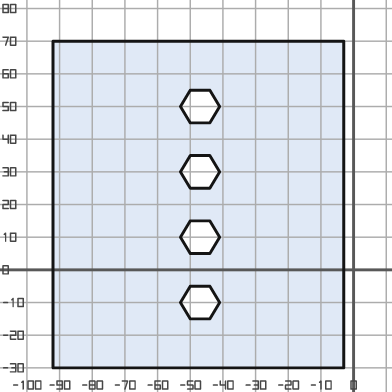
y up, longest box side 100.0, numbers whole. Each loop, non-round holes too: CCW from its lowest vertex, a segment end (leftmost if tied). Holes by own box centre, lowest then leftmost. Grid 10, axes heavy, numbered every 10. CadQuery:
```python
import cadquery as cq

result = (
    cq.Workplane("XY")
    .moveTo(-92.0, -30.0)
    .lineTo(-3.0, -30.0)
    .lineTo(-3.0, 70.0)
    .lineTo(-92.0, 70.0)
    .close()
    .moveTo(-50.0, -15.0)
    .lineTo(-44.0, -15.0)
    .lineTo(-41.0, -10.0)
    .lineTo(-44.0, -5.0)
    .lineTo(-50.0, -5.0)
    .lineTo(-53.0, -10.0)
    .close()
    .moveTo(-50.0, 5.0)
    .lineTo(-44.0, 5.0)
    .lineTo(-41.0, 10.0)
    .lineTo(-44.0, 15.0)
    .lineTo(-50.0, 15.0)
    .lineTo(-53.0, 10.0)
    .close()
    .moveTo(-50.0, 25.0)
    .lineTo(-44.0, 25.0)
    .lineTo(-41.0, 30.0)
    .lineTo(-44.0, 35.0)
    .lineTo(-50.0, 35.0)
    .lineTo(-53.0, 30.0)
    .close()
    .moveTo(-50.0, 45.0)
    .lineTo(-44.0, 45.0)
    .lineTo(-41.0, 50.0)
    .lineTo(-44.0, 55.0)
    .lineTo(-50.0, 55.0)
    .lineTo(-53.0, 50.0)
    .close()
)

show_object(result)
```